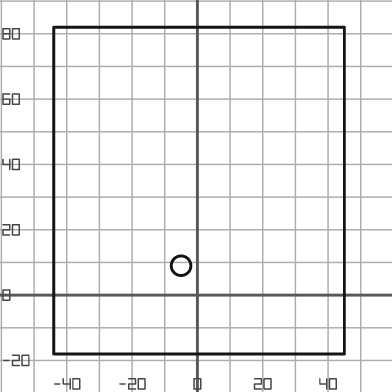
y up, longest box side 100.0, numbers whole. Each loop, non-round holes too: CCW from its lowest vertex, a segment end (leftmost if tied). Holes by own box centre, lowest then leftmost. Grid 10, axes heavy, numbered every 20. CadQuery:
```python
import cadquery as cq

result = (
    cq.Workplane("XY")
    .moveTo(-44.0, -18.0)
    .lineTo(45.0, -18.0)
    .lineTo(45.0, 82.0)
    .lineTo(-44.0, 82.0)
    .close()
    .moveTo(-5.0, 9.0)
    .circle(3.0)
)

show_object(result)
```